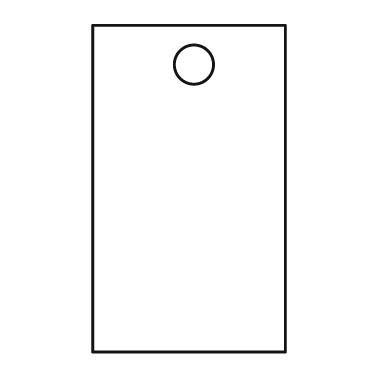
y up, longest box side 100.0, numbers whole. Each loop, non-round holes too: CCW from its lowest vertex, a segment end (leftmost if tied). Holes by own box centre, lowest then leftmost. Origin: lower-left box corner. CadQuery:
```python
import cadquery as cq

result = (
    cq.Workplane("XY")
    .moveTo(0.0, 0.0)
    .lineTo(59.0, 0.0)
    .lineTo(59.0, 100.0)
    .lineTo(0.0, 100.0)
    .close()
    .moveTo(31.0, 88.0)
    .circle(6.0)
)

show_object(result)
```